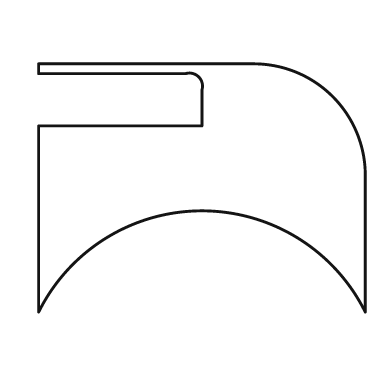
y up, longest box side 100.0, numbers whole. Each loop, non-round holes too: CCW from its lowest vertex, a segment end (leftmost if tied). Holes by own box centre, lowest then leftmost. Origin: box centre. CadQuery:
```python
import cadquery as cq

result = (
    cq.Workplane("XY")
    .moveTo(-50.0, -38.0)
    .threePointArc((0.0, -7.0), (50.0, -38.0))
    .lineTo(50.0, 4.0)
    .threePointArc((40.0, 28.0), (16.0, 38.0))
    .lineTo(-50.0, 38.0)
    .lineTo(-50.0, 35.0)
    .lineTo(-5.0, 35.0)
    .threePointArc((-1.0, 34.0), (0.0, 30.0))
    .lineTo(0.0, 19.0)
    .lineTo(-50.0, 19.0)
    .close()
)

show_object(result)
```